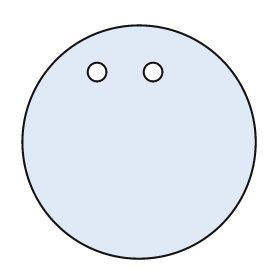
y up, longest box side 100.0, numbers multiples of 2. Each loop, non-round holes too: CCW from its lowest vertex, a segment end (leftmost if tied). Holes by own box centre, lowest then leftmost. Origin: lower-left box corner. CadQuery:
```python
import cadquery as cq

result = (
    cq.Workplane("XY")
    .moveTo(50.0, 50.0)
    .circle(50.0)
    .moveTo(32.0, 80.0)
    .circle(4.0)
    .moveTo(56.0, 80.0)
    .circle(4.0)
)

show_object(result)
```